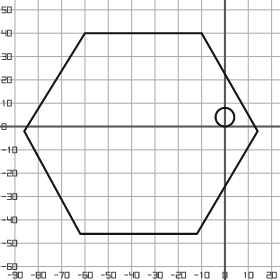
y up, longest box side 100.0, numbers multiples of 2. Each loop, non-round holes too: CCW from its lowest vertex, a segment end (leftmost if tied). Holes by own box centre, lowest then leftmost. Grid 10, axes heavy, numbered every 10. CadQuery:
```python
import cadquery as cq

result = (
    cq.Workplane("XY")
    .moveTo(-62.0, -46.0)
    .lineTo(-12.0, -46.0)
    .lineTo(14.0, -2.0)
    .lineTo(-10.0, 40.0)
    .lineTo(-60.0, 40.0)
    .lineTo(-86.0, -2.0)
    .close()
    .moveTo(0.0, 4.0)
    .circle(4.0)
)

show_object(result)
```